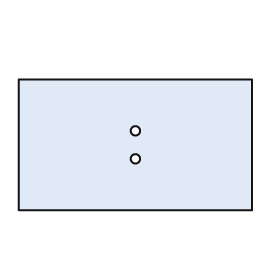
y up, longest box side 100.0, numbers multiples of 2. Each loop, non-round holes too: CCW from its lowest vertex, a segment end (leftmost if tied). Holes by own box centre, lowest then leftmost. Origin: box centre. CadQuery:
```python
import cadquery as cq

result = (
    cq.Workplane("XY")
    .moveTo(-50.0, -28.0)
    .lineTo(50.0, -28.0)
    .lineTo(50.0, 28.0)
    .lineTo(-50.0, 28.0)
    .close()
    .moveTo(0.0, -6.0)
    .circle(2.0)
    .moveTo(0.0, 6.0)
    .circle(2.0)
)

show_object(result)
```